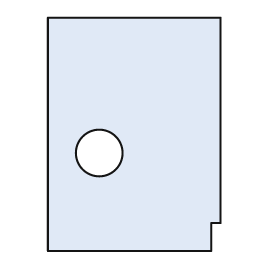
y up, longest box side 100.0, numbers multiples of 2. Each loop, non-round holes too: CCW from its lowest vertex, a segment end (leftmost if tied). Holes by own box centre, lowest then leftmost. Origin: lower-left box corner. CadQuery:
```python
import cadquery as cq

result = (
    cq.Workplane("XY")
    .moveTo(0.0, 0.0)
    .lineTo(70.0, 0.0)
    .lineTo(70.0, 12.0)
    .lineTo(74.0, 12.0)
    .lineTo(74.0, 100.0)
    .lineTo(0.0, 100.0)
    .close()
    .moveTo(22.0, 42.0)
    .circle(10.0)
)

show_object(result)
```